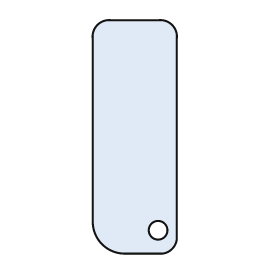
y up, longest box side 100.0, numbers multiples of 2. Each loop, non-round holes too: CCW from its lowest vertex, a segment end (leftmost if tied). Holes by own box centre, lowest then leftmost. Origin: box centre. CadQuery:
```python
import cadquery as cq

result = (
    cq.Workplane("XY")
    .moveTo(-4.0, -50.0)
    .lineTo(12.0, -50.0)
    .threePointArc((16.0, -48.0), (18.0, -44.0))
    .lineTo(18.0, 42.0)
    .threePointArc((16.0, 48.0), (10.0, 50.0))
    .lineTo(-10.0, 50.0)
    .threePointArc((-16.0, 48.0), (-18.0, 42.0))
    .lineTo(-18.0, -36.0)
    .threePointArc((-14.0, -46.0), (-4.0, -50.0))
    .close()
    .moveTo(10.0, -40.0)
    .circle(4.0)
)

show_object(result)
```